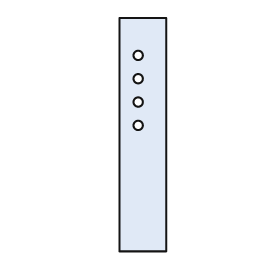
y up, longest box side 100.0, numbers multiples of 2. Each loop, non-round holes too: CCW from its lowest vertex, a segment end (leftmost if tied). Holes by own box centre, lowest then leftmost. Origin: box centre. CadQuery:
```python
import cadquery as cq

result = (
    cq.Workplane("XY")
    .moveTo(-10.0, -50.0)
    .lineTo(10.0, -50.0)
    .lineTo(10.0, 50.0)
    .lineTo(-10.0, 50.0)
    .close()
    .moveTo(-2.0, 4.0)
    .circle(2.0)
    .moveTo(-2.0, 14.0)
    .circle(2.0)
    .moveTo(-2.0, 24.0)
    .circle(2.0)
    .moveTo(-2.0, 34.0)
    .circle(2.0)
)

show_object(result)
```